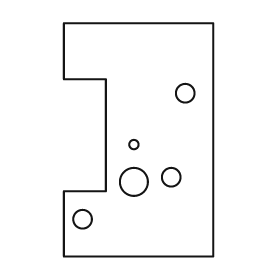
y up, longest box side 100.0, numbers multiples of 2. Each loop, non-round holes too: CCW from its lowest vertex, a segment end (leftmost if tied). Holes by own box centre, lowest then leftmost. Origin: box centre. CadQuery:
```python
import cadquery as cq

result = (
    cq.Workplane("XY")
    .moveTo(-32.0, -50.0)
    .lineTo(32.0, -50.0)
    .lineTo(32.0, 50.0)
    .lineTo(-32.0, 50.0)
    .lineTo(-32.0, 26.0)
    .lineTo(-14.0, 26.0)
    .lineTo(-14.0, -22.0)
    .lineTo(-32.0, -22.0)
    .close()
    .moveTo(-24.0, -34.0)
    .circle(4.0)
    .moveTo(-2.0, -18.0)
    .circle(6.0)
    .moveTo(14.0, -16.0)
    .circle(4.0)
    .moveTo(-2.0, -2.0)
    .circle(2.0)
    .moveTo(20.0, 20.0)
    .circle(4.0)
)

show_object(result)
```